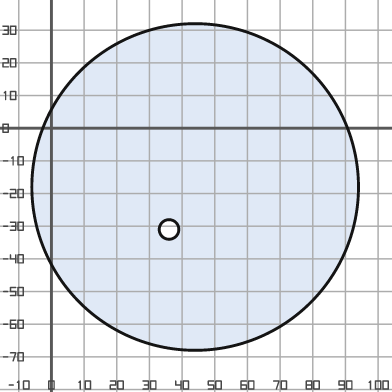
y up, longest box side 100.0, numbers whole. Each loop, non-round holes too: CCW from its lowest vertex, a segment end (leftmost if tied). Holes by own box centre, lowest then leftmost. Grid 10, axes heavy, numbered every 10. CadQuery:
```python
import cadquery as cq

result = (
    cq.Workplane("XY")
    .moveTo(44.0, -18.0)
    .circle(50.0)
    .moveTo(36.0, -31.0)
    .circle(3.0)
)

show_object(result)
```